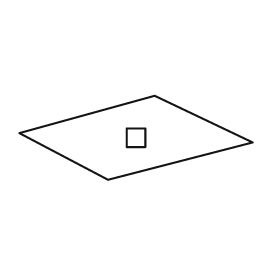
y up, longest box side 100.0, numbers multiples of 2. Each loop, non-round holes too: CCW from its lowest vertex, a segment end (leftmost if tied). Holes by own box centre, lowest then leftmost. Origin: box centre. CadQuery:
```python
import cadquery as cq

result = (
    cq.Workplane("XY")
    .moveTo(-12.0, -18.0)
    .lineTo(50.0, -2.0)
    .lineTo(8.0, 18.0)
    .lineTo(-50.0, 2.0)
    .close()
    .moveTo(-4.0, -4.0)
    .lineTo(4.0, -4.0)
    .lineTo(4.0, 4.0)
    .lineTo(-4.0, 4.0)
    .close()
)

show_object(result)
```